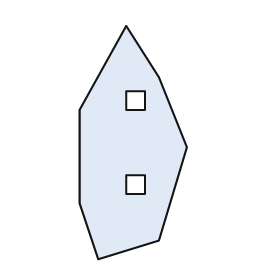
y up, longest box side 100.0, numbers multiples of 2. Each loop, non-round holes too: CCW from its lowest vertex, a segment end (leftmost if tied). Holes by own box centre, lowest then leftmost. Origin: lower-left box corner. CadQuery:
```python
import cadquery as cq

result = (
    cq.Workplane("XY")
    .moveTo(8.0, 0.0)
    .lineTo(34.0, 8.0)
    .lineTo(46.0, 48.0)
    .lineTo(34.0, 78.0)
    .lineTo(20.0, 100.0)
    .lineTo(0.0, 64.0)
    .lineTo(0.0, 24.0)
    .close()
    .moveTo(20.0, 28.0)
    .lineTo(28.0, 28.0)
    .lineTo(28.0, 36.0)
    .lineTo(20.0, 36.0)
    .close()
    .moveTo(20.0, 64.0)
    .lineTo(28.0, 64.0)
    .lineTo(28.0, 72.0)
    .lineTo(20.0, 72.0)
    .close()
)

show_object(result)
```